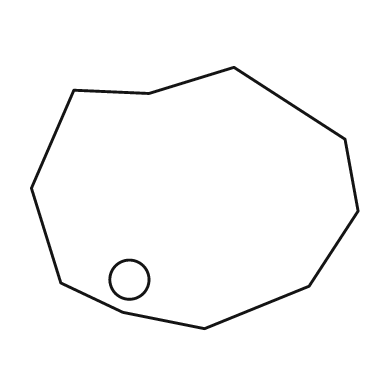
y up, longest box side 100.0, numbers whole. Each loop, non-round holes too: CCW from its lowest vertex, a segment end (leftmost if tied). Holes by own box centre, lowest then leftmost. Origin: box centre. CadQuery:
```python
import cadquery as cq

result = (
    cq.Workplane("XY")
    .moveTo(3.0, -40.0)
    .lineTo(35.0, -27.0)
    .lineTo(50.0, -4.0)
    .lineTo(46.0, 18.0)
    .lineTo(12.0, 40.0)
    .lineTo(-14.0, 32.0)
    .lineTo(-37.0, 33.0)
    .lineTo(-50.0, 3.0)
    .lineTo(-41.0, -26.0)
    .lineTo(-22.0, -35.0)
    .close()
    .moveTo(-20.0, -25.0)
    .circle(6.0)
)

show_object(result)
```